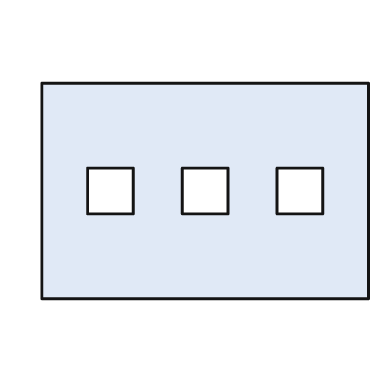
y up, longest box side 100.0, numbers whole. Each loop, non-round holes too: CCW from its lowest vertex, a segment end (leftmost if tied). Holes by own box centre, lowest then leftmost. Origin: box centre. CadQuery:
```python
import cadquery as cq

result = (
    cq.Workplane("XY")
    .moveTo(-50.0, -33.0)
    .lineTo(50.0, -33.0)
    .lineTo(50.0, 33.0)
    .lineTo(-50.0, 33.0)
    .close()
    .moveTo(-36.0, -7.0)
    .lineTo(-22.0, -7.0)
    .lineTo(-22.0, 7.0)
    .lineTo(-36.0, 7.0)
    .close()
    .moveTo(-7.0, -7.0)
    .lineTo(7.0, -7.0)
    .lineTo(7.0, 7.0)
    .lineTo(-7.0, 7.0)
    .close()
    .moveTo(22.0, -7.0)
    .lineTo(36.0, -7.0)
    .lineTo(36.0, 7.0)
    .lineTo(22.0, 7.0)
    .close()
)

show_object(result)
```